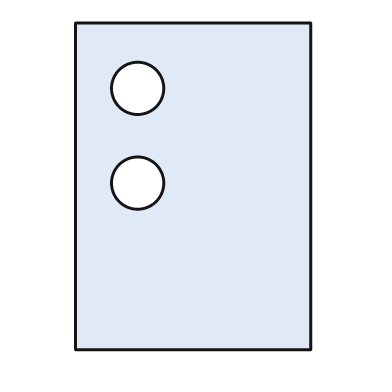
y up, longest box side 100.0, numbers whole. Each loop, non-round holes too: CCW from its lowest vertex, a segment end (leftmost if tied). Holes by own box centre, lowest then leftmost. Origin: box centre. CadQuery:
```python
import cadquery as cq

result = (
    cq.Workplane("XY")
    .moveTo(-36.0, -50.0)
    .lineTo(36.0, -50.0)
    .lineTo(36.0, 50.0)
    .lineTo(-36.0, 50.0)
    .close()
    .moveTo(-17.0, 1.0)
    .circle(8.0)
    .moveTo(-17.0, 30.0)
    .circle(8.0)
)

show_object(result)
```